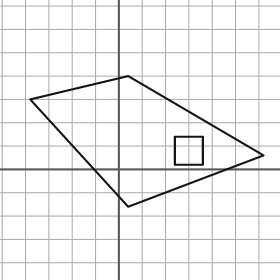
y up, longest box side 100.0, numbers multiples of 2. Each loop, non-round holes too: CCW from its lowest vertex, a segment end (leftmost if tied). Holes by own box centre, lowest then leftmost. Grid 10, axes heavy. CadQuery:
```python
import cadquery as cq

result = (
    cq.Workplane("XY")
    .moveTo(4.0, -16.0)
    .lineTo(62.0, 6.0)
    .lineTo(4.0, 40.0)
    .lineTo(-38.0, 30.0)
    .close()
    .moveTo(24.0, 2.0)
    .lineTo(36.0, 2.0)
    .lineTo(36.0, 14.0)
    .lineTo(24.0, 14.0)
    .close()
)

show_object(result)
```